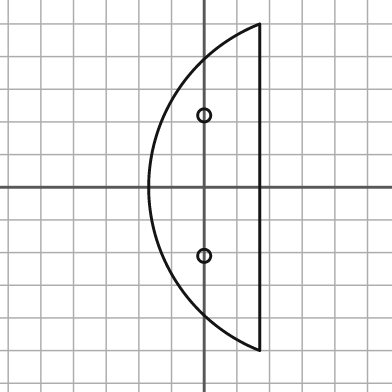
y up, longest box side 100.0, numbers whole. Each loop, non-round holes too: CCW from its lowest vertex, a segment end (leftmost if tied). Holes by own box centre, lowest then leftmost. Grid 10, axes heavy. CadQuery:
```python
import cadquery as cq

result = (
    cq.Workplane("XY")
    .moveTo(17.0, -50.0)
    .lineTo(17.0, 50.0)
    .threePointArc((-17.0, 0.0), (17.0, -50.0))
    .close()
    .moveTo(0.0, -21.0)
    .circle(2.0)
    .moveTo(0.0, 22.0)
    .circle(2.0)
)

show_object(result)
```